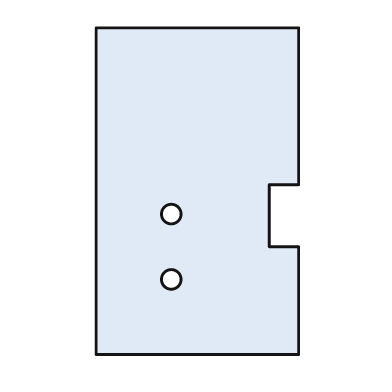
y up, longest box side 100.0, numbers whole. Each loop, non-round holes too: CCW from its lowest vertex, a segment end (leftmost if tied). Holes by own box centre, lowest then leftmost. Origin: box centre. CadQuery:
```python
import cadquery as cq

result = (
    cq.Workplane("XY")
    .moveTo(-31.0, -50.0)
    .lineTo(31.0, -50.0)
    .lineTo(31.0, -17.0)
    .lineTo(22.0, -17.0)
    .lineTo(22.0, 2.0)
    .lineTo(31.0, 2.0)
    .lineTo(31.0, 50.0)
    .lineTo(-31.0, 50.0)
    .close()
    .moveTo(-8.0, -27.0)
    .circle(3.0)
    .moveTo(-8.0, -7.0)
    .circle(3.0)
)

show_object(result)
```